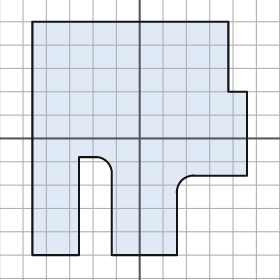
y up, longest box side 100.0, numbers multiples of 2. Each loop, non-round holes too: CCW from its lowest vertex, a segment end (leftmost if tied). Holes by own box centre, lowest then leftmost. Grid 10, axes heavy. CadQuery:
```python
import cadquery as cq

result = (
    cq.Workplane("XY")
    .moveTo(-46.0, -50.0)
    .lineTo(-26.0, -50.0)
    .lineTo(-26.0, -8.0)
    .lineTo(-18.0, -8.0)
    .threePointArc((-14.0, -10.0), (-12.0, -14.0))
    .lineTo(-12.0, -50.0)
    .lineTo(16.0, -50.0)
    .lineTo(16.0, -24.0)
    .threePointArc((18.0, -18.0), (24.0, -16.0))
    .lineTo(46.0, -16.0)
    .lineTo(46.0, 20.0)
    .lineTo(38.0, 20.0)
    .lineTo(38.0, 50.0)
    .lineTo(-46.0, 50.0)
    .close()
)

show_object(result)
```